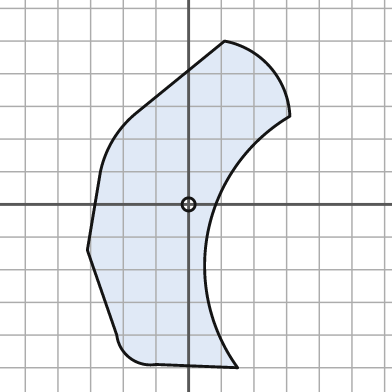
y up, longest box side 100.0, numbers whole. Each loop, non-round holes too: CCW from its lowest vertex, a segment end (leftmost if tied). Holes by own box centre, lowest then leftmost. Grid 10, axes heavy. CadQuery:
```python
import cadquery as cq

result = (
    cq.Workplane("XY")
    .moveTo(15.0, -50.0)
    .threePointArc((6.0, -8.0), (31.0, 27.0))
    .threePointArc((25.0, 42.0), (11.0, 50.0))
    .lineTo(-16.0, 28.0)
    .threePointArc((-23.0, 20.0), (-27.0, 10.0))
    .lineTo(-31.0, -14.0)
    .lineTo(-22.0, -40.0)
    .threePointArc((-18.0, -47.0), (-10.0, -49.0))
    .close()
    .moveTo(0.0, 0.0)
    .circle(2.0)
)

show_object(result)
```